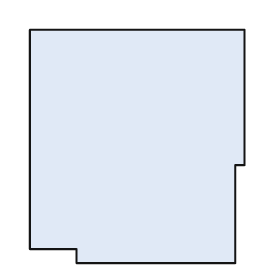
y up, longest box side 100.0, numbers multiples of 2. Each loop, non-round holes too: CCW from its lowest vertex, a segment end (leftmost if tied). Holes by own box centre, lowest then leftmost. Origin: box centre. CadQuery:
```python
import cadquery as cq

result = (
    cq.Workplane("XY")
    .moveTo(-26.0, -50.0)
    .lineTo(42.0, -50.0)
    .lineTo(42.0, -8.0)
    .lineTo(46.0, -8.0)
    .lineTo(46.0, 50.0)
    .lineTo(-46.0, 50.0)
    .lineTo(-46.0, -44.0)
    .lineTo(-26.0, -44.0)
    .close()
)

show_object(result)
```